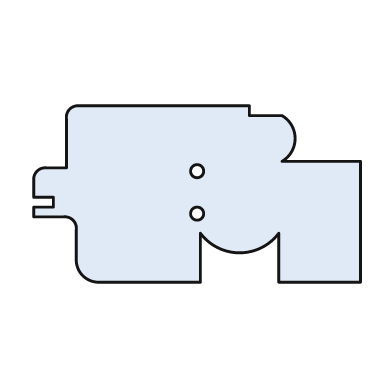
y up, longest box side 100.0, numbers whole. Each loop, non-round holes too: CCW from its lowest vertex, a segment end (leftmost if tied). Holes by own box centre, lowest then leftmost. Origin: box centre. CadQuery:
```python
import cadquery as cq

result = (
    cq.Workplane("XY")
    .moveTo(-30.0, -27.0)
    .lineTo(1.0, -27.0)
    .lineTo(1.0, -12.0)
    .threePointArc((13.0, -18.0), (25.0, -12.0))
    .lineTo(25.0, -27.0)
    .lineTo(50.0, -27.0)
    .lineTo(50.0, 10.0)
    .lineTo(26.0, 10.0)
    .threePointArc((30.0, 17.0), (26.0, 24.0))
    .lineTo(16.0, 24.0)
    .lineTo(16.0, 27.0)
    .lineTo(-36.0, 27.0)
    .threePointArc((-39.0, 26.0), (-40.0, 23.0))
    .lineTo(-40.0, 8.0)
    .lineTo(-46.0, 8.0)
    .threePointArc((-49.0, 7.0), (-50.0, 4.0))
    .lineTo(-50.0, -1.0)
    .lineTo(-44.0, -1.0)
    .lineTo(-44.0, -4.0)
    .lineTo(-50.0, -4.0)
    .lineTo(-50.0, -7.0)
    .lineTo(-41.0, -7.0)
    .threePointArc((-38.0, -8.0), (-37.0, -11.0))
    .lineTo(-37.0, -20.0)
    .threePointArc((-35.0, -25.0), (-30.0, -27.0))
    .close()
    .moveTo(0.0, -6.0)
    .circle(2.0)
    .moveTo(0.0, 7.0)
    .circle(2.0)
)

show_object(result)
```